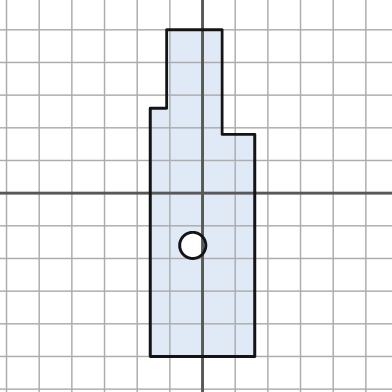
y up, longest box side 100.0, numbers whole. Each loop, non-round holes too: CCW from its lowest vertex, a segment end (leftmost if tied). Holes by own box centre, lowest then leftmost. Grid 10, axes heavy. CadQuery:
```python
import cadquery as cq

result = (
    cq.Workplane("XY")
    .moveTo(-16.0, -50.0)
    .lineTo(16.0, -50.0)
    .lineTo(16.0, 18.0)
    .lineTo(6.0, 18.0)
    .lineTo(6.0, 50.0)
    .lineTo(-11.0, 50.0)
    .lineTo(-11.0, 26.0)
    .lineTo(-16.0, 26.0)
    .close()
    .moveTo(-3.0, -16.0)
    .circle(4.0)
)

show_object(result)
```